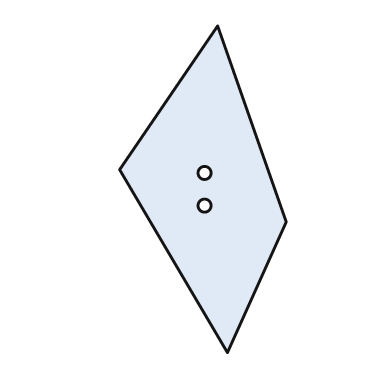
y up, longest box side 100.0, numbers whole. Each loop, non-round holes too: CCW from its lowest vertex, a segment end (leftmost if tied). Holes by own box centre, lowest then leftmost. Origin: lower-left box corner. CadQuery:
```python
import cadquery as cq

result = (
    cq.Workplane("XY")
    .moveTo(33.0, 0.0)
    .lineTo(51.0, 40.0)
    .lineTo(30.0, 100.0)
    .lineTo(0.0, 56.0)
    .close()
    .moveTo(26.0, 45.0)
    .circle(2.0)
    .moveTo(26.0, 55.0)
    .circle(2.0)
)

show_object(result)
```